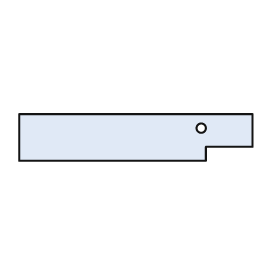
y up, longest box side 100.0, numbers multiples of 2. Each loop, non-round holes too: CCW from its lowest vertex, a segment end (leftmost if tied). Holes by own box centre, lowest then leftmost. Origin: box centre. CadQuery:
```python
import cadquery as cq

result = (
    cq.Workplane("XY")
    .moveTo(-50.0, -10.0)
    .lineTo(30.0, -10.0)
    .lineTo(30.0, -4.0)
    .lineTo(50.0, -4.0)
    .lineTo(50.0, 10.0)
    .lineTo(-50.0, 10.0)
    .close()
    .moveTo(28.0, 4.0)
    .circle(2.0)
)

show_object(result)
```